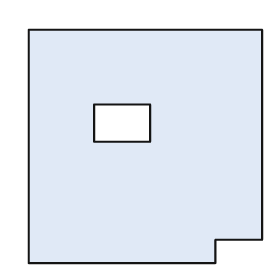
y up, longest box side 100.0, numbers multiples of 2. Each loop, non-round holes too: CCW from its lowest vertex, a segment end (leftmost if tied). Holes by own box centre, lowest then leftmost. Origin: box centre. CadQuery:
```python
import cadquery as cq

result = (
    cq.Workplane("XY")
    .moveTo(-50.0, -50.0)
    .lineTo(30.0, -50.0)
    .lineTo(30.0, -40.0)
    .lineTo(50.0, -40.0)
    .lineTo(50.0, 50.0)
    .lineTo(-50.0, 50.0)
    .close()
    .moveTo(-22.0, 2.0)
    .lineTo(2.0, 2.0)
    .lineTo(2.0, 18.0)
    .lineTo(-22.0, 18.0)
    .close()
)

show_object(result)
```